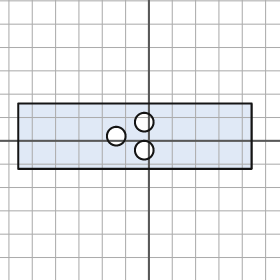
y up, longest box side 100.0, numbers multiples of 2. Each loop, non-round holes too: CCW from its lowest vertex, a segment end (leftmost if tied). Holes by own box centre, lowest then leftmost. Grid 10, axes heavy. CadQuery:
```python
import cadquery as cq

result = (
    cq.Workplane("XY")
    .moveTo(-56.0, -12.0)
    .lineTo(44.0, -12.0)
    .lineTo(44.0, 16.0)
    .lineTo(-56.0, 16.0)
    .close()
    .moveTo(-2.0, -4.0)
    .circle(4.0)
    .moveTo(-14.0, 2.0)
    .circle(4.0)
    .moveTo(-2.0, 8.0)
    .circle(4.0)
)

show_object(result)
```